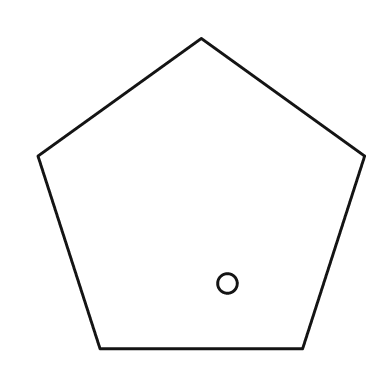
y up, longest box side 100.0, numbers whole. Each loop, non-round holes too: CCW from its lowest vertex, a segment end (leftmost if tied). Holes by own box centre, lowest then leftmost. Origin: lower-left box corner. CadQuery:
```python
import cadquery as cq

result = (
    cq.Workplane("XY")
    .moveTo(19.0, 0.0)
    .lineTo(81.0, 0.0)
    .lineTo(100.0, 59.0)
    .lineTo(50.0, 95.0)
    .lineTo(0.0, 59.0)
    .close()
    .moveTo(58.0, 20.0)
    .circle(3.0)
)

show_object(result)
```